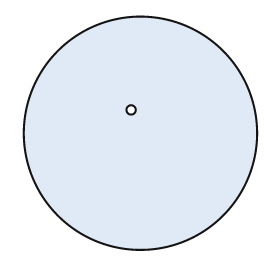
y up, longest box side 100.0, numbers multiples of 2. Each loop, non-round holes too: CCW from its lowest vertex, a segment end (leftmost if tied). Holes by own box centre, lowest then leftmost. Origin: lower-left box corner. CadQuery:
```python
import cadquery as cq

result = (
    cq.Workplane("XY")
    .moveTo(50.0, 50.0)
    .circle(50.0)
    .moveTo(46.0, 60.0)
    .circle(2.0)
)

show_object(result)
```